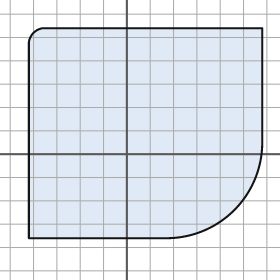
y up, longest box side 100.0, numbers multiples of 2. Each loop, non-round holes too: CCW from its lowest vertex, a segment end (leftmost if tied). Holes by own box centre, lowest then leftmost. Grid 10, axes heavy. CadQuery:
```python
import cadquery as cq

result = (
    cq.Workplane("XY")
    .moveTo(-42.0, -36.0)
    .lineTo(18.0, -36.0)
    .threePointArc((46.0, -24.0), (58.0, 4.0))
    .lineTo(58.0, 54.0)
    .lineTo(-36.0, 54.0)
    .threePointArc((-40.0, 52.0), (-42.0, 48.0))
    .close()
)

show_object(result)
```